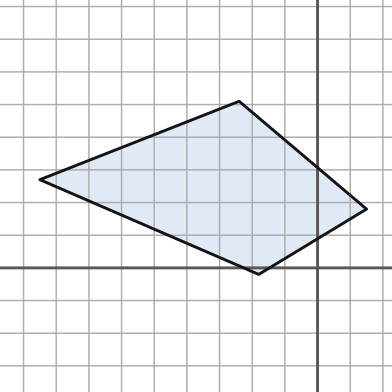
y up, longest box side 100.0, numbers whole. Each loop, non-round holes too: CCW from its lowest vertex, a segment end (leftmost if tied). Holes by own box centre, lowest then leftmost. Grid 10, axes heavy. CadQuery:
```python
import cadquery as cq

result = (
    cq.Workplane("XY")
    .moveTo(-18.0, -2.0)
    .lineTo(15.0, 18.0)
    .lineTo(-24.0, 51.0)
    .lineTo(-85.0, 27.0)
    .close()
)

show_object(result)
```